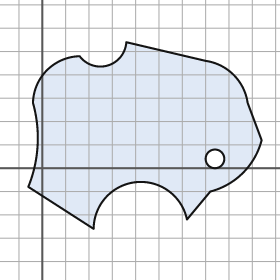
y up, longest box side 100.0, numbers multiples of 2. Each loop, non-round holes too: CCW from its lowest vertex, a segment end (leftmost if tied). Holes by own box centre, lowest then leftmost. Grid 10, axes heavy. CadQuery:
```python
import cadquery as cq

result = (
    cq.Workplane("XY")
    .moveTo(22.0, -26.0)
    .threePointArc((40.0, -6.0), (62.0, -22.0))
    .lineTo(72.0, -10.0)
    .threePointArc((86.0, -2.0), (94.0, 12.0))
    .lineTo(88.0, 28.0)
    .threePointArc((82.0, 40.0), (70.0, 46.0))
    .lineTo(36.0, 54.0)
    .threePointArc((28.0, 44.0), (16.0, 48.0))
    .threePointArc((2.0, 42.0), (-4.0, 28.0))
    .threePointArc((-2.0, 10.0), (-6.0, -8.0))
    .close()
    .moveTo(74.0, 4.0)
    .circle(4.0)
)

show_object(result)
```